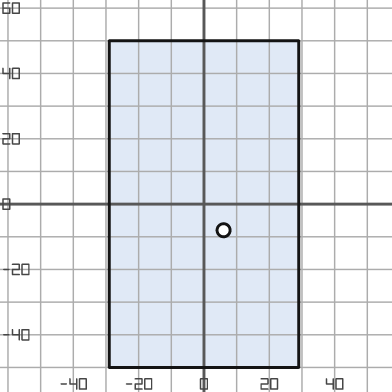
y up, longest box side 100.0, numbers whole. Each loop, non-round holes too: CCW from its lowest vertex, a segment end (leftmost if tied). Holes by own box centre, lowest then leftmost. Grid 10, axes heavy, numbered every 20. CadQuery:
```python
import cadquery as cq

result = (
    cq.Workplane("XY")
    .moveTo(-29.0, -50.0)
    .lineTo(29.0, -50.0)
    .lineTo(29.0, 50.0)
    .lineTo(-29.0, 50.0)
    .close()
    .moveTo(6.0, -8.0)
    .circle(2.0)
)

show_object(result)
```